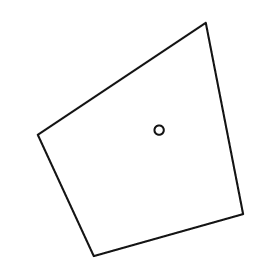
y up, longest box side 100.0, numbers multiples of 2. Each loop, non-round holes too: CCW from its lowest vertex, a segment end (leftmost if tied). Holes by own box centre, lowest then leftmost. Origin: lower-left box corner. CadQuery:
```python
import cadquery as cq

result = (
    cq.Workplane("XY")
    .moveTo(24.0, 0.0)
    .lineTo(88.0, 18.0)
    .lineTo(72.0, 100.0)
    .lineTo(0.0, 52.0)
    .close()
    .moveTo(52.0, 54.0)
    .circle(2.0)
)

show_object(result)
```